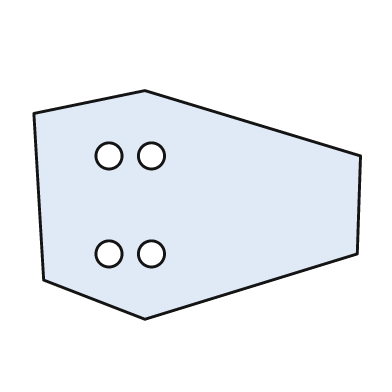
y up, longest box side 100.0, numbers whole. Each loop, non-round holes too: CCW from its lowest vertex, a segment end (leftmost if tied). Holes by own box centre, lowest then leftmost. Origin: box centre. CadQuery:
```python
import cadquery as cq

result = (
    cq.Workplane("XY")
    .moveTo(-16.0, -35.0)
    .lineTo(49.0, -15.0)
    .lineTo(50.0, 15.0)
    .lineTo(-16.0, 35.0)
    .lineTo(-50.0, 28.0)
    .lineTo(-47.0, -23.0)
    .close()
    .moveTo(-27.0, -15.0)
    .circle(4.0)
    .moveTo(-14.0, -15.0)
    .circle(4.0)
    .moveTo(-27.0, 15.0)
    .circle(4.0)
    .moveTo(-14.0, 15.0)
    .circle(4.0)
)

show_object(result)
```